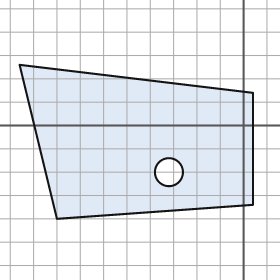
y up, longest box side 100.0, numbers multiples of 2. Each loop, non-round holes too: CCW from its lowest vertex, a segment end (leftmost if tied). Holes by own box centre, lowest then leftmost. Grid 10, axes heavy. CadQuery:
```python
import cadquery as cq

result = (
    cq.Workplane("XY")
    .moveTo(-80.0, -40.0)
    .lineTo(4.0, -34.0)
    .lineTo(4.0, 14.0)
    .lineTo(-96.0, 26.0)
    .close()
    .moveTo(-32.0, -20.0)
    .circle(6.0)
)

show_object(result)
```